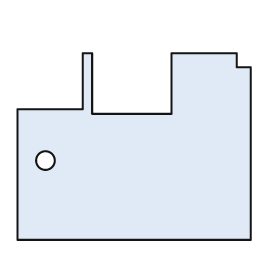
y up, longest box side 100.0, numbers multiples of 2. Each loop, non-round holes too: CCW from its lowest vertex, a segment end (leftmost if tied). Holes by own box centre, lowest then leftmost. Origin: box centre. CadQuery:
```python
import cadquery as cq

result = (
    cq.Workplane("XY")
    .moveTo(-50.0, -40.0)
    .lineTo(50.0, -40.0)
    .lineTo(50.0, 34.0)
    .lineTo(44.0, 34.0)
    .lineTo(44.0, 40.0)
    .lineTo(16.0, 40.0)
    .lineTo(16.0, 14.0)
    .lineTo(-18.0, 14.0)
    .lineTo(-18.0, 40.0)
    .lineTo(-22.0, 40.0)
    .lineTo(-22.0, 16.0)
    .lineTo(-50.0, 16.0)
    .close()
    .moveTo(-38.0, -6.0)
    .circle(4.0)
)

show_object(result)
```